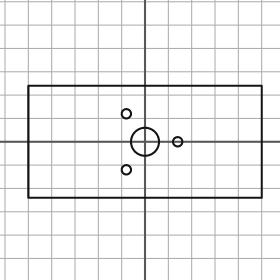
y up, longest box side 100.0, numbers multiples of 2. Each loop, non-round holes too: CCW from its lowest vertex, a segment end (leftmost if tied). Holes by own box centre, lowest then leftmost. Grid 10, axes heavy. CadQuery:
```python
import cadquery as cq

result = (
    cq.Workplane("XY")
    .moveTo(-50.0, -24.0)
    .lineTo(50.0, -24.0)
    .lineTo(50.0, 24.0)
    .lineTo(-50.0, 24.0)
    .close()
    .moveTo(-8.0, -12.0)
    .circle(2.0)
    .moveTo(0.0, 0.0)
    .circle(6.0)
    .moveTo(14.0, 0.0)
    .circle(2.0)
    .moveTo(-8.0, 12.0)
    .circle(2.0)
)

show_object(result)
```